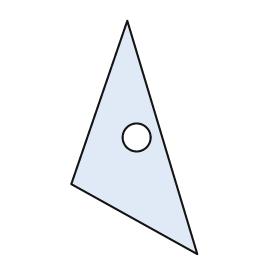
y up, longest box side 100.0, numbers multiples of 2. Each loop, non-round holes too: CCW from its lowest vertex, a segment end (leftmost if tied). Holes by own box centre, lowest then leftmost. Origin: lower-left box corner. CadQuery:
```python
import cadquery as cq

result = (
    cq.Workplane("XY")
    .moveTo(54.0, 0.0)
    .lineTo(24.0, 100.0)
    .lineTo(0.0, 30.0)
    .close()
    .moveTo(28.0, 50.0)
    .circle(6.0)
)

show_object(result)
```